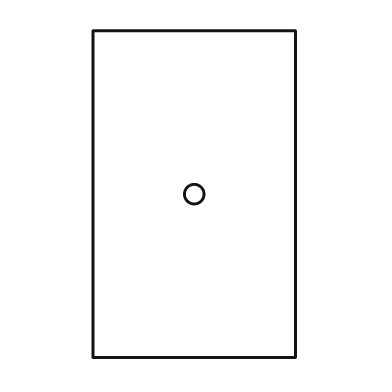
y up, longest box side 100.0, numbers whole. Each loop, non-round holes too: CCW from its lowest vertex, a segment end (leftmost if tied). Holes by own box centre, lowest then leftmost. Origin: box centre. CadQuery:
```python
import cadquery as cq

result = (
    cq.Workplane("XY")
    .moveTo(-31.0, -50.0)
    .lineTo(31.0, -50.0)
    .lineTo(31.0, 50.0)
    .lineTo(-31.0, 50.0)
    .close()
    .moveTo(0.0, 0.0)
    .circle(3.0)
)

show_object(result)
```